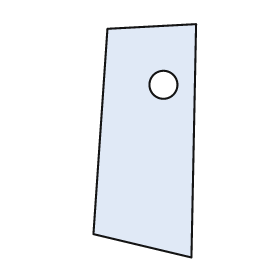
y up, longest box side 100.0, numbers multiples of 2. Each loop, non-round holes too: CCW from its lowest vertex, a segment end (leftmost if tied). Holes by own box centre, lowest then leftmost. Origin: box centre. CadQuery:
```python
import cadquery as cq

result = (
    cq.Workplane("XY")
    .moveTo(20.0, -50.0)
    .lineTo(22.0, 50.0)
    .lineTo(-16.0, 48.0)
    .lineTo(-22.0, -40.0)
    .close()
    .moveTo(8.0, 24.0)
    .circle(6.0)
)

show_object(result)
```